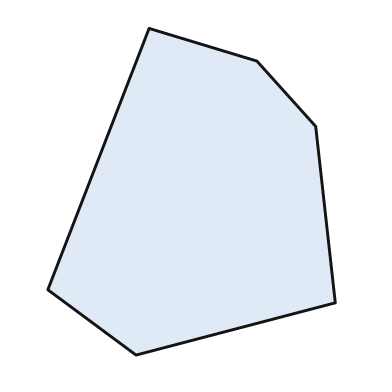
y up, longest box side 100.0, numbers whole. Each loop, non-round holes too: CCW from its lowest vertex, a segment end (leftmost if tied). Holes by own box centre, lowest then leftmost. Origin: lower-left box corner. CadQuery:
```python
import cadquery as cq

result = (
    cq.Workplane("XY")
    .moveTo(27.0, 0.0)
    .lineTo(88.0, 16.0)
    .lineTo(82.0, 70.0)
    .lineTo(64.0, 90.0)
    .lineTo(31.0, 100.0)
    .lineTo(0.0, 20.0)
    .close()
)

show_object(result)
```